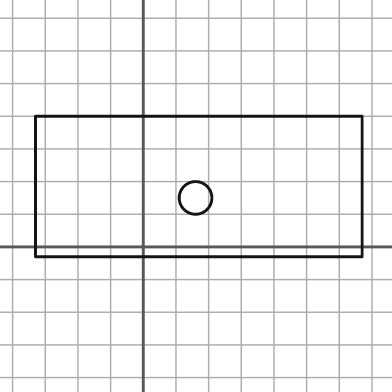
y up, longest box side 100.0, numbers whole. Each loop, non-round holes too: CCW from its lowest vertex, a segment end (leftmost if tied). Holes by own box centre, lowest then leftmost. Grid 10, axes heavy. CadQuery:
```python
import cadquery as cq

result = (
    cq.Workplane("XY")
    .moveTo(-33.0, -3.0)
    .lineTo(67.0, -3.0)
    .lineTo(67.0, 40.0)
    .lineTo(-33.0, 40.0)
    .close()
    .moveTo(16.0, 15.0)
    .circle(5.0)
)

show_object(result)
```